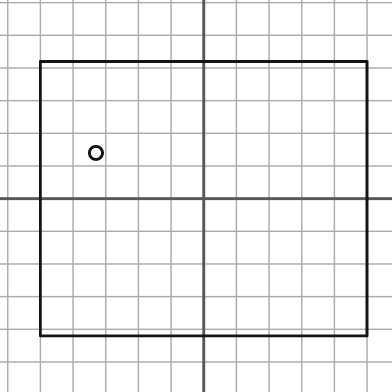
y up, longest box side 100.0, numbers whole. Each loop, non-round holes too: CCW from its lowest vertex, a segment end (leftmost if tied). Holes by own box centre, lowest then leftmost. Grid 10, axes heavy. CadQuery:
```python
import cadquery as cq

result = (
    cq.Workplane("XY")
    .moveTo(-50.0, -42.0)
    .lineTo(50.0, -42.0)
    .lineTo(50.0, 42.0)
    .lineTo(-50.0, 42.0)
    .close()
    .moveTo(-33.0, 14.0)
    .circle(2.0)
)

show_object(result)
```